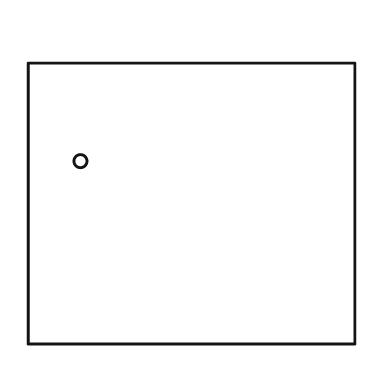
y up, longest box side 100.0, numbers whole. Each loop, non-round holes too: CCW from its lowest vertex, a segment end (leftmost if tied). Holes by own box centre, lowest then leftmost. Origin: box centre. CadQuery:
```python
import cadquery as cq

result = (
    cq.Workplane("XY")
    .moveTo(-50.0, -43.0)
    .lineTo(50.0, -43.0)
    .lineTo(50.0, 43.0)
    .lineTo(-50.0, 43.0)
    .close()
    .moveTo(-34.0, 13.0)
    .circle(2.0)
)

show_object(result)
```